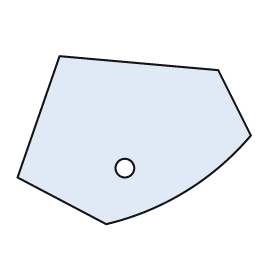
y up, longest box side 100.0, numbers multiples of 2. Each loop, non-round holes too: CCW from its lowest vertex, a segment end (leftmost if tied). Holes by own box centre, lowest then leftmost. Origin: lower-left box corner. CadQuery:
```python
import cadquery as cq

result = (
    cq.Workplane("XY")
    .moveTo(38.0, 0.0)
    .threePointArc((72.0, 14.0), (100.0, 38.0))
    .lineTo(86.0, 66.0)
    .lineTo(18.0, 72.0)
    .lineTo(0.0, 20.0)
    .close()
    .moveTo(46.0, 24.0)
    .circle(4.0)
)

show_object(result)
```